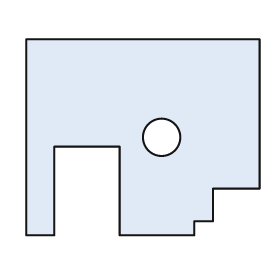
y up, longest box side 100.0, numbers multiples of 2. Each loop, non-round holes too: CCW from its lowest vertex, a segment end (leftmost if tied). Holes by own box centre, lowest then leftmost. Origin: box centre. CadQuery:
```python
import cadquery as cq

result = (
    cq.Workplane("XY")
    .moveTo(-50.0, -42.0)
    .lineTo(-38.0, -42.0)
    .lineTo(-38.0, -4.0)
    .lineTo(-10.0, -4.0)
    .lineTo(-10.0, -42.0)
    .lineTo(22.0, -42.0)
    .lineTo(22.0, -36.0)
    .lineTo(30.0, -36.0)
    .lineTo(30.0, -22.0)
    .lineTo(50.0, -22.0)
    .lineTo(50.0, 42.0)
    .lineTo(-50.0, 42.0)
    .close()
    .moveTo(8.0, 0.0)
    .circle(8.0)
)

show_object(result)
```